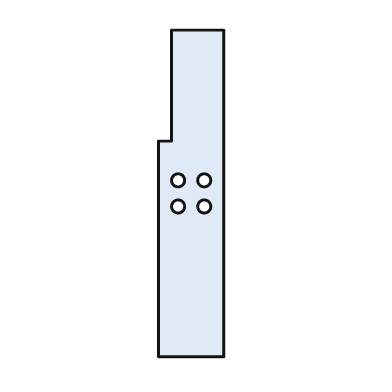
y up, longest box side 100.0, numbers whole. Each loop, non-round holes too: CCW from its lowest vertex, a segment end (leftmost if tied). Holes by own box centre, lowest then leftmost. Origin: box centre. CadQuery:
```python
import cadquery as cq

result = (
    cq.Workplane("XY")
    .moveTo(-10.0, -50.0)
    .lineTo(10.0, -50.0)
    .lineTo(10.0, 50.0)
    .lineTo(-6.0, 50.0)
    .lineTo(-6.0, 16.0)
    .lineTo(-10.0, 16.0)
    .close()
    .moveTo(-4.0, -4.0)
    .circle(2.0)
    .moveTo(4.0, -4.0)
    .circle(2.0)
    .moveTo(-4.0, 4.0)
    .circle(2.0)
    .moveTo(4.0, 4.0)
    .circle(2.0)
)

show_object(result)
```